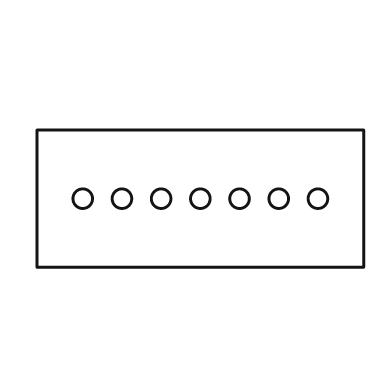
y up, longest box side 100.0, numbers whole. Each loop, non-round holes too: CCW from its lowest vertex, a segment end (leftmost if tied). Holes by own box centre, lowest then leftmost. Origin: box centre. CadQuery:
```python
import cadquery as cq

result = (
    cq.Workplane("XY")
    .moveTo(-50.0, -21.0)
    .lineTo(50.0, -21.0)
    .lineTo(50.0, 21.0)
    .lineTo(-50.0, 21.0)
    .close()
    .moveTo(-36.0, 0.0)
    .circle(3.0)
    .moveTo(-24.0, 0.0)
    .circle(3.0)
    .moveTo(-12.0, 0.0)
    .circle(3.0)
    .moveTo(0.0, 0.0)
    .circle(3.0)
    .moveTo(12.0, 0.0)
    .circle(3.0)
    .moveTo(24.0, 0.0)
    .circle(3.0)
    .moveTo(36.0, 0.0)
    .circle(3.0)
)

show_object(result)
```